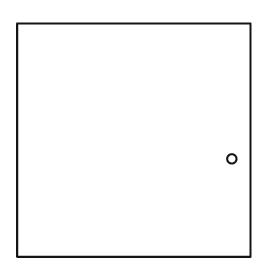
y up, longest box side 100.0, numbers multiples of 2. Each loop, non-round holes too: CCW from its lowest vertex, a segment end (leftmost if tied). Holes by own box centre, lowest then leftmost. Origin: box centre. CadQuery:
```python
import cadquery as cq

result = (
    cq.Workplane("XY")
    .moveTo(-50.0, -50.0)
    .lineTo(50.0, -50.0)
    .lineTo(50.0, 50.0)
    .lineTo(-50.0, 50.0)
    .close()
    .moveTo(42.0, -8.0)
    .circle(2.0)
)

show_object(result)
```